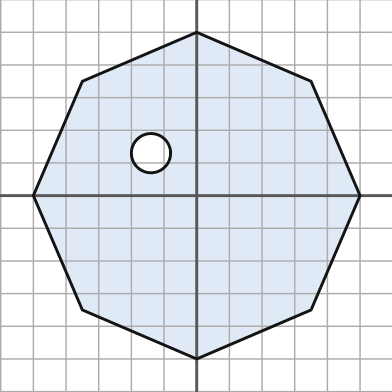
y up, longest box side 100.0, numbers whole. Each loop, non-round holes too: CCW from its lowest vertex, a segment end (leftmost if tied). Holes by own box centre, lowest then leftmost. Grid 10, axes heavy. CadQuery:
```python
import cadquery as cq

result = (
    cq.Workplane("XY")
    .moveTo(0.0, -50.0)
    .lineTo(35.0, -35.0)
    .lineTo(50.0, 0.0)
    .lineTo(35.0, 35.0)
    .lineTo(0.0, 50.0)
    .lineTo(-35.0, 35.0)
    .lineTo(-50.0, 0.0)
    .lineTo(-35.0, -35.0)
    .close()
    .moveTo(-14.0, 13.0)
    .circle(6.0)
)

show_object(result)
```